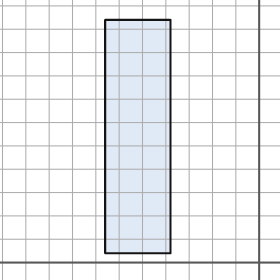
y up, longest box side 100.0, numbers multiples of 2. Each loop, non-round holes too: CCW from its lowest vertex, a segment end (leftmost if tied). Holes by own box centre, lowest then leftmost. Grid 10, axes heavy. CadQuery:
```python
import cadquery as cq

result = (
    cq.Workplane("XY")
    .moveTo(-66.0, 4.0)
    .lineTo(-38.0, 4.0)
    .lineTo(-38.0, 104.0)
    .lineTo(-66.0, 104.0)
    .close()
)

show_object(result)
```